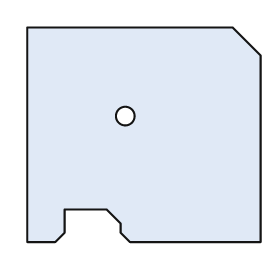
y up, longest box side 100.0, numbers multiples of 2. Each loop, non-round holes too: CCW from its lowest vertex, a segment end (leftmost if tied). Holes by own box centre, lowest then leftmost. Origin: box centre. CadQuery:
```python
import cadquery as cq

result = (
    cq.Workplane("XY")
    .moveTo(-50.0, -46.0)
    .lineTo(-38.0, -46.0)
    .lineTo(-34.0, -42.0)
    .lineTo(-34.0, -32.0)
    .lineTo(-16.0, -32.0)
    .lineTo(-10.0, -38.0)
    .lineTo(-10.0, -42.0)
    .lineTo(-6.0, -46.0)
    .lineTo(50.0, -46.0)
    .lineTo(50.0, 34.0)
    .lineTo(38.0, 46.0)
    .lineTo(-50.0, 46.0)
    .close()
    .moveTo(-8.0, 8.0)
    .circle(4.0)
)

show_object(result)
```